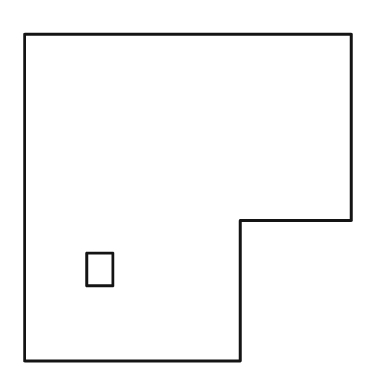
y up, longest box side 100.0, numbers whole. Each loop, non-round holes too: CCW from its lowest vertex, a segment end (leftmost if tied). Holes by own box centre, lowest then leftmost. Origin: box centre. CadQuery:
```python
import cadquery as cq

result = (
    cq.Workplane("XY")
    .moveTo(-50.0, -50.0)
    .lineTo(16.0, -50.0)
    .lineTo(16.0, -7.0)
    .lineTo(50.0, -7.0)
    .lineTo(50.0, 50.0)
    .lineTo(-50.0, 50.0)
    .close()
    .moveTo(-31.0, -27.0)
    .lineTo(-23.0, -27.0)
    .lineTo(-23.0, -17.0)
    .lineTo(-31.0, -17.0)
    .close()
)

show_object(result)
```